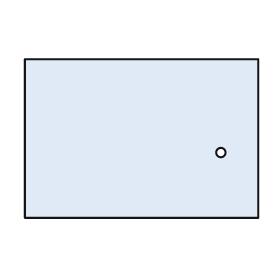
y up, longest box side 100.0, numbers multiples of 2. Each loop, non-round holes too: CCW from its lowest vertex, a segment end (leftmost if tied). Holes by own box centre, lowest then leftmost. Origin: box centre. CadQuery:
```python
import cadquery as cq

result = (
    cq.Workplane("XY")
    .moveTo(-50.0, -34.0)
    .lineTo(50.0, -34.0)
    .lineTo(50.0, 34.0)
    .lineTo(-50.0, 34.0)
    .close()
    .moveTo(34.0, -6.0)
    .circle(2.0)
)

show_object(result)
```